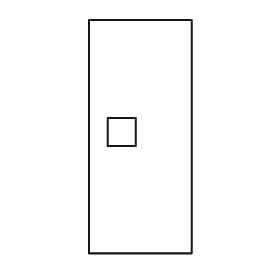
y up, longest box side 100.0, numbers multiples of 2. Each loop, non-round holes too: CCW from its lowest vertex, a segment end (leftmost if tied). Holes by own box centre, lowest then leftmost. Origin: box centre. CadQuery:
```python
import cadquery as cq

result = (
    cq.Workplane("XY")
    .moveTo(-22.0, -50.0)
    .lineTo(22.0, -50.0)
    .lineTo(22.0, 50.0)
    .lineTo(-22.0, 50.0)
    .close()
    .moveTo(-14.0, -4.0)
    .lineTo(-2.0, -4.0)
    .lineTo(-2.0, 8.0)
    .lineTo(-14.0, 8.0)
    .close()
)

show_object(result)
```